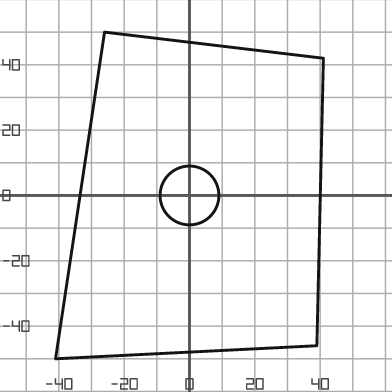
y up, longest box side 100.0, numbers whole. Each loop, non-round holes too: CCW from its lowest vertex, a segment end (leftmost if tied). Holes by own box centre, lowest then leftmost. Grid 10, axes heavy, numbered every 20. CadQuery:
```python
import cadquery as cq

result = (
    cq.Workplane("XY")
    .moveTo(-41.0, -50.0)
    .lineTo(39.0, -46.0)
    .lineTo(41.0, 42.0)
    .lineTo(-26.0, 50.0)
    .close()
    .moveTo(0.0, 0.0)
    .circle(9.0)
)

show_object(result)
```